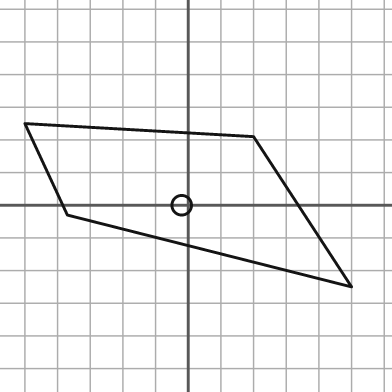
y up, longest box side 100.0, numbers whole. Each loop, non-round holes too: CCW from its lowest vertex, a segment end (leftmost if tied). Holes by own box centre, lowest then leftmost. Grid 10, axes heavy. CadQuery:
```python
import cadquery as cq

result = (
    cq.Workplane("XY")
    .moveTo(50.0, -25.0)
    .lineTo(20.0, 21.0)
    .lineTo(-50.0, 25.0)
    .lineTo(-37.0, -3.0)
    .close()
    .moveTo(-2.0, 0.0)
    .circle(3.0)
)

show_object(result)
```